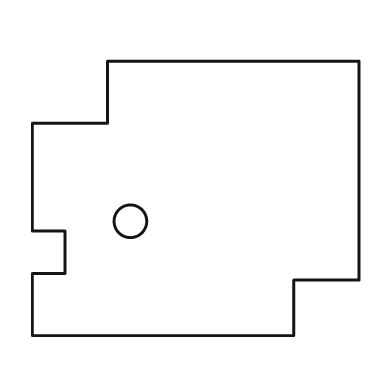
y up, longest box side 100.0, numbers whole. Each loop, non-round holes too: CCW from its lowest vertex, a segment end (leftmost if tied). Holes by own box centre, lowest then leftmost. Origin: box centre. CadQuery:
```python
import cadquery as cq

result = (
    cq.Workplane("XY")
    .moveTo(-50.0, -42.0)
    .lineTo(30.0, -42.0)
    .lineTo(30.0, -25.0)
    .lineTo(50.0, -25.0)
    .lineTo(50.0, 42.0)
    .lineTo(-27.0, 42.0)
    .lineTo(-27.0, 23.0)
    .lineTo(-50.0, 23.0)
    .lineTo(-50.0, -10.0)
    .lineTo(-40.0, -10.0)
    .lineTo(-40.0, -23.0)
    .lineTo(-50.0, -23.0)
    .close()
    .moveTo(-20.0, -7.0)
    .circle(5.0)
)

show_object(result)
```